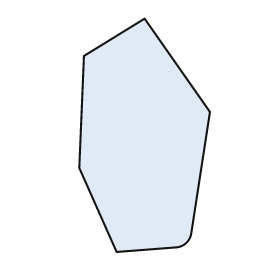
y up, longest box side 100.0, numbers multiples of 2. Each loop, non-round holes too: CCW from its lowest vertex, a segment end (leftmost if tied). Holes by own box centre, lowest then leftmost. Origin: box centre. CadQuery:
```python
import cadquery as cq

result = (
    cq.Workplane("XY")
    .moveTo(-12.0, -50.0)
    .lineTo(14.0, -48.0)
    .threePointArc((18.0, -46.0), (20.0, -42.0))
    .lineTo(28.0, 10.0)
    .lineTo(0.0, 50.0)
    .lineTo(-26.0, 34.0)
    .lineTo(-28.0, -14.0)
    .close()
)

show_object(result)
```